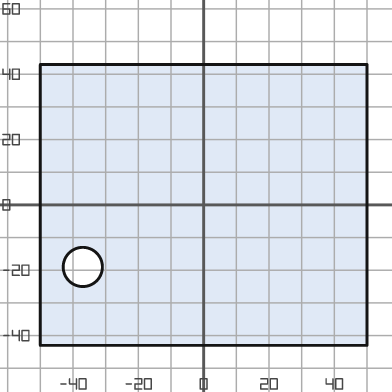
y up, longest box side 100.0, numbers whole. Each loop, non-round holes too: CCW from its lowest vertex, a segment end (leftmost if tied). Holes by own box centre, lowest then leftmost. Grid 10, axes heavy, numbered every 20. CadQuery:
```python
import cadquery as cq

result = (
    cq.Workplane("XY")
    .moveTo(-50.0, -43.0)
    .lineTo(50.0, -43.0)
    .lineTo(50.0, 43.0)
    .lineTo(-50.0, 43.0)
    .close()
    .moveTo(-37.0, -19.0)
    .circle(6.0)
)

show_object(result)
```